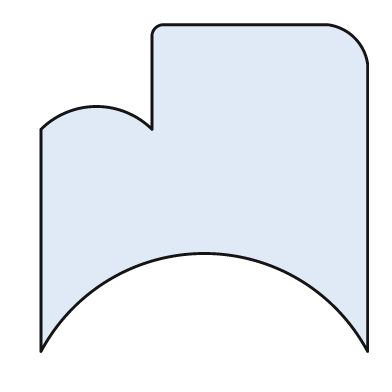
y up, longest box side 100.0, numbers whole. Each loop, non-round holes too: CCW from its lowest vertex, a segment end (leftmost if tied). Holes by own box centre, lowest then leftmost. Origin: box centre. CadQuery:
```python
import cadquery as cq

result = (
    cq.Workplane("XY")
    .moveTo(-50.0, -50.0)
    .threePointArc((0.0, -20.0), (50.0, -50.0))
    .lineTo(50.0, 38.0)
    .threePointArc((46.0, 46.0), (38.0, 50.0))
    .lineTo(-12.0, 50.0)
    .threePointArc((-15.0, 49.0), (-16.0, 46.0))
    .lineTo(-16.0, 18.0)
    .threePointArc((-33.0, 25.0), (-50.0, 18.0))
    .close()
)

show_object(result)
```